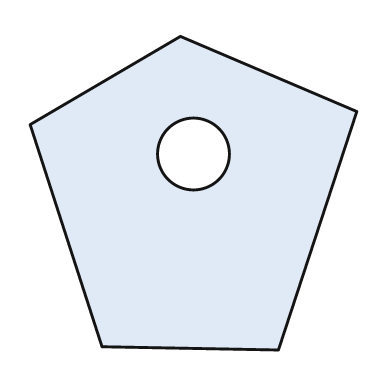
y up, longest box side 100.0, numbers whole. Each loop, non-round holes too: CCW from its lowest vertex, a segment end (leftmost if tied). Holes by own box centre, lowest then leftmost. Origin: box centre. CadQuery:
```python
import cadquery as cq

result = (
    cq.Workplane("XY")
    .moveTo(26.0, -48.0)
    .lineTo(50.0, 25.0)
    .lineTo(-4.0, 48.0)
    .lineTo(-50.0, 21.0)
    .lineTo(-28.0, -47.0)
    .close()
    .moveTo(0.0, 12.0)
    .circle(11.0)
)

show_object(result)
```